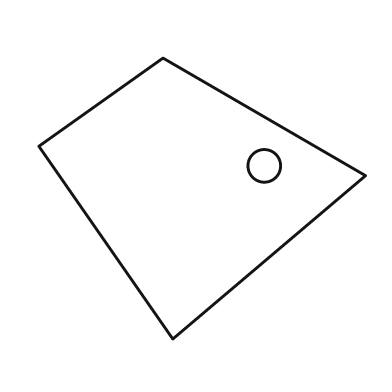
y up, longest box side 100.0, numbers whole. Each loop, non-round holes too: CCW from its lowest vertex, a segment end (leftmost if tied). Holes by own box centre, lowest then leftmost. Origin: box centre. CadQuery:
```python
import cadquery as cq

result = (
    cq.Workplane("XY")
    .moveTo(-9.0, -43.0)
    .lineTo(50.0, 7.0)
    .lineTo(-12.0, 43.0)
    .lineTo(-50.0, 16.0)
    .close()
    .moveTo(19.0, 10.0)
    .circle(5.0)
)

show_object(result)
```